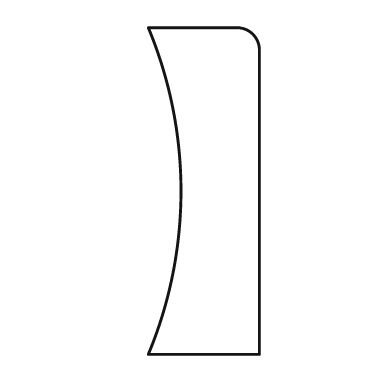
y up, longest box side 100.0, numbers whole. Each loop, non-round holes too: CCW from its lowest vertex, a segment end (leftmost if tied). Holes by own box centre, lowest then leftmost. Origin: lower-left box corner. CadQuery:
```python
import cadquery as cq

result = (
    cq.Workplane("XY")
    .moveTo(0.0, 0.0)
    .lineTo(34.0, 0.0)
    .lineTo(34.0, 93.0)
    .threePointArc((32.0, 98.0), (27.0, 100.0))
    .lineTo(0.0, 100.0)
    .threePointArc((10.0, 50.0), (0.0, 0.0))
    .close()
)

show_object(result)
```